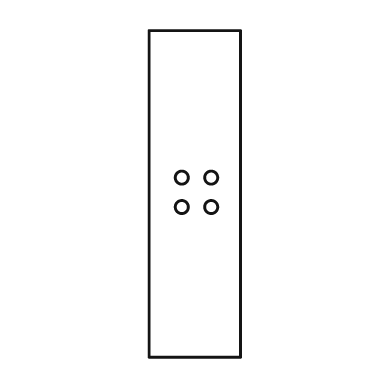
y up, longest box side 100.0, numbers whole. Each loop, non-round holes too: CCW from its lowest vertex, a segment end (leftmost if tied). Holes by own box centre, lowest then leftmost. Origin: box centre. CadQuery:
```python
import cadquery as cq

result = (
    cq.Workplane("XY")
    .moveTo(-14.0, -50.0)
    .lineTo(14.0, -50.0)
    .lineTo(14.0, 50.0)
    .lineTo(-14.0, 50.0)
    .close()
    .moveTo(-4.0, -4.0)
    .circle(2.0)
    .moveTo(5.0, -4.0)
    .circle(2.0)
    .moveTo(-4.0, 5.0)
    .circle(2.0)
    .moveTo(5.0, 5.0)
    .circle(2.0)
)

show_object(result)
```